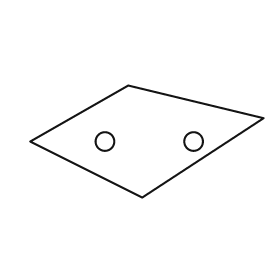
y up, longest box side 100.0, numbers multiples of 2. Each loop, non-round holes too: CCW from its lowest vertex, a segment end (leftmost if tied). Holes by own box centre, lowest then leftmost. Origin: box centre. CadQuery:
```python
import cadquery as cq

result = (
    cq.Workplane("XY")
    .moveTo(-2.0, -24.0)
    .lineTo(50.0, 10.0)
    .lineTo(-8.0, 24.0)
    .lineTo(-50.0, 0.0)
    .close()
    .moveTo(-18.0, 0.0)
    .circle(4.0)
    .moveTo(20.0, 0.0)
    .circle(4.0)
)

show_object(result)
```